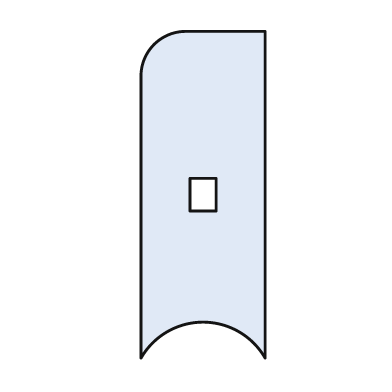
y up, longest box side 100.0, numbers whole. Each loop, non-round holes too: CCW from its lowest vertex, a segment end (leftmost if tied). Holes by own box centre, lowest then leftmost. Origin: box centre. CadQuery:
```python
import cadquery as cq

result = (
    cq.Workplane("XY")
    .moveTo(-19.0, -50.0)
    .threePointArc((0.0, -39.0), (19.0, -50.0))
    .lineTo(19.0, 50.0)
    .lineTo(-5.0, 50.0)
    .threePointArc((-15.0, 46.0), (-19.0, 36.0))
    .close()
    .moveTo(-4.0, -5.0)
    .lineTo(4.0, -5.0)
    .lineTo(4.0, 5.0)
    .lineTo(-4.0, 5.0)
    .close()
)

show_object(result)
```